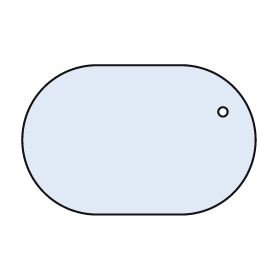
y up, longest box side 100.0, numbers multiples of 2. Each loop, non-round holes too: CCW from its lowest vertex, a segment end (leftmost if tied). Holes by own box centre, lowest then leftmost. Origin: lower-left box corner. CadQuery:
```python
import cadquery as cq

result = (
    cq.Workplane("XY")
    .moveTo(32.0, 0.0)
    .lineTo(68.0, 0.0)
    .threePointArc((100.0, 32.0), (68.0, 64.0))
    .lineTo(32.0, 64.0)
    .threePointArc((0.0, 32.0), (32.0, 0.0))
    .close()
    .moveTo(86.0, 44.0)
    .circle(2.0)
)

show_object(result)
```